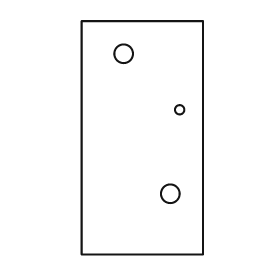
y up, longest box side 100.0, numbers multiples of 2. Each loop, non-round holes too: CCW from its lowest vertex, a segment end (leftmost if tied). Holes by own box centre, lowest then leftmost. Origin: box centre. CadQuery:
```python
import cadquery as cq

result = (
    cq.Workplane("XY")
    .moveTo(-26.0, -50.0)
    .lineTo(26.0, -50.0)
    .lineTo(26.0, 50.0)
    .lineTo(-26.0, 50.0)
    .close()
    .moveTo(12.0, -24.0)
    .circle(4.0)
    .moveTo(16.0, 12.0)
    .circle(2.0)
    .moveTo(-8.0, 36.0)
    .circle(4.0)
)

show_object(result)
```